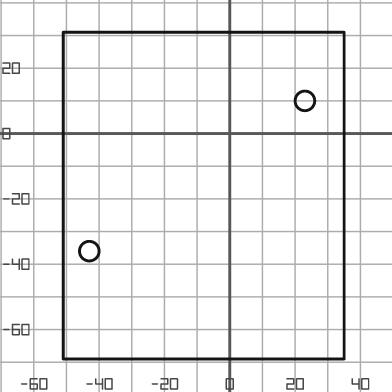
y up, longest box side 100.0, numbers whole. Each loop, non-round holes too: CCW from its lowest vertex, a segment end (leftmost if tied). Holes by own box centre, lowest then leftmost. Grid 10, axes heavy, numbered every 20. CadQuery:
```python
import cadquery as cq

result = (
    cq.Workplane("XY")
    .moveTo(-51.0, -69.0)
    .lineTo(35.0, -69.0)
    .lineTo(35.0, 31.0)
    .lineTo(-51.0, 31.0)
    .close()
    .moveTo(-43.0, -36.0)
    .circle(3.0)
    .moveTo(23.0, 10.0)
    .circle(3.0)
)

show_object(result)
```